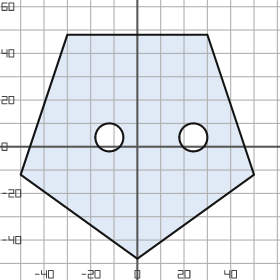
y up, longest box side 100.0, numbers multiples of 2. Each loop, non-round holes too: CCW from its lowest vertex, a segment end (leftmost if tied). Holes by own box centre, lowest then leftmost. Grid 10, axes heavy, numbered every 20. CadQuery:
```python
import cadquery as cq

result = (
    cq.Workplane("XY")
    .moveTo(0.0, -48.0)
    .lineTo(50.0, -12.0)
    .lineTo(30.0, 48.0)
    .lineTo(-30.0, 48.0)
    .lineTo(-50.0, -12.0)
    .close()
    .moveTo(-12.0, 4.0)
    .circle(6.0)
    .moveTo(24.0, 4.0)
    .circle(6.0)
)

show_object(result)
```